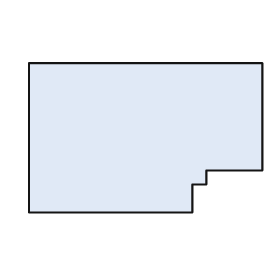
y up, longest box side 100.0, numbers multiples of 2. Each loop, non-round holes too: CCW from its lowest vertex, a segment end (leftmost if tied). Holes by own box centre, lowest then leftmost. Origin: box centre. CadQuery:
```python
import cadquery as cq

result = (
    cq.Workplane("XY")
    .moveTo(-50.0, -32.0)
    .lineTo(20.0, -32.0)
    .lineTo(20.0, -20.0)
    .lineTo(26.0, -20.0)
    .lineTo(26.0, -14.0)
    .lineTo(50.0, -14.0)
    .lineTo(50.0, 32.0)
    .lineTo(-50.0, 32.0)
    .close()
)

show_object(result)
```